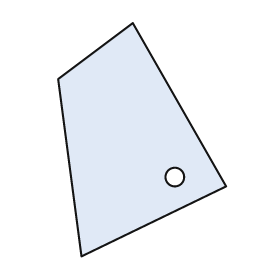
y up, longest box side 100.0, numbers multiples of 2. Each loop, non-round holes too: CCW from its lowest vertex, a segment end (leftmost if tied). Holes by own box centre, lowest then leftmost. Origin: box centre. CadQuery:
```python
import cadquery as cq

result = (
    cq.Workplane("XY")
    .moveTo(-26.0, -50.0)
    .lineTo(36.0, -20.0)
    .lineTo(-4.0, 50.0)
    .lineTo(-36.0, 26.0)
    .close()
    .moveTo(14.0, -16.0)
    .circle(4.0)
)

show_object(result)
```